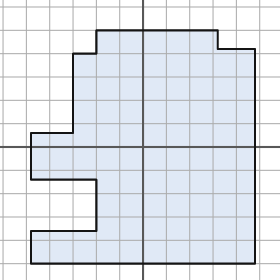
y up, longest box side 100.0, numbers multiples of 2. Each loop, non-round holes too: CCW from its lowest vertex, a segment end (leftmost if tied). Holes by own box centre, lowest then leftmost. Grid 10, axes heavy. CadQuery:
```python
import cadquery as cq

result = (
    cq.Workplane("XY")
    .moveTo(-48.0, -50.0)
    .lineTo(48.0, -50.0)
    .lineTo(48.0, 42.0)
    .lineTo(32.0, 42.0)
    .lineTo(32.0, 50.0)
    .lineTo(-20.0, 50.0)
    .lineTo(-20.0, 40.0)
    .lineTo(-30.0, 40.0)
    .lineTo(-30.0, 6.0)
    .lineTo(-48.0, 6.0)
    .lineTo(-48.0, -14.0)
    .lineTo(-20.0, -14.0)
    .lineTo(-20.0, -36.0)
    .lineTo(-48.0, -36.0)
    .close()
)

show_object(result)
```